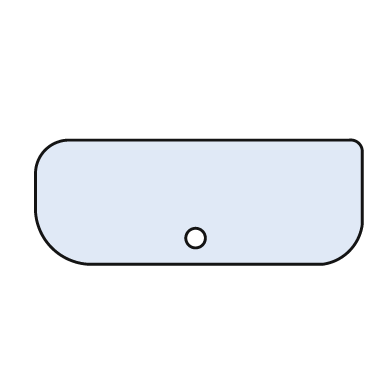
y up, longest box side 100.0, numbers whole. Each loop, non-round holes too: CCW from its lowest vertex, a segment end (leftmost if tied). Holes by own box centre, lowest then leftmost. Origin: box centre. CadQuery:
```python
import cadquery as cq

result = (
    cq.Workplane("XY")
    .moveTo(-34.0, -19.0)
    .lineTo(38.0, -19.0)
    .threePointArc((46.0, -15.0), (50.0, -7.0))
    .lineTo(50.0, 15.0)
    .threePointArc((49.0, 18.0), (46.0, 19.0))
    .lineTo(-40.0, 19.0)
    .threePointArc((-47.0, 16.0), (-50.0, 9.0))
    .lineTo(-50.0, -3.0)
    .threePointArc((-45.0, -14.0), (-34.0, -19.0))
    .close()
    .moveTo(-1.0, -11.0)
    .circle(3.0)
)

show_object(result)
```